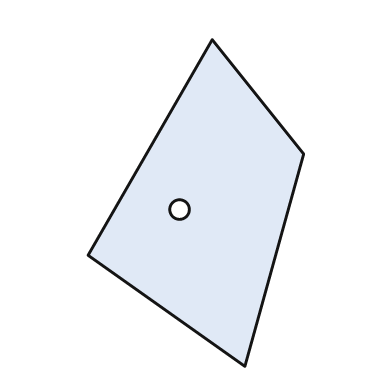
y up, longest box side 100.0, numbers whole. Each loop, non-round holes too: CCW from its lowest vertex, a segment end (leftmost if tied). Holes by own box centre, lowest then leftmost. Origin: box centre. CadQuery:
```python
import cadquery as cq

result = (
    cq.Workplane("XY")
    .moveTo(15.0, -50.0)
    .lineTo(33.0, 15.0)
    .lineTo(5.0, 50.0)
    .lineTo(-33.0, -16.0)
    .close()
    .moveTo(-5.0, -2.0)
    .circle(3.0)
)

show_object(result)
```